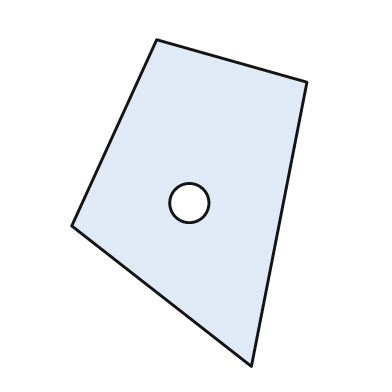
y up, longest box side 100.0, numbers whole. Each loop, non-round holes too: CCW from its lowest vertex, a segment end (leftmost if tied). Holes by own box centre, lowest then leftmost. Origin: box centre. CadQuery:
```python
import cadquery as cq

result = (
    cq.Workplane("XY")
    .moveTo(19.0, -50.0)
    .lineTo(36.0, 37.0)
    .lineTo(-10.0, 50.0)
    .lineTo(-36.0, -7.0)
    .close()
    .moveTo(0.0, 0.0)
    .circle(6.0)
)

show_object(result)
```